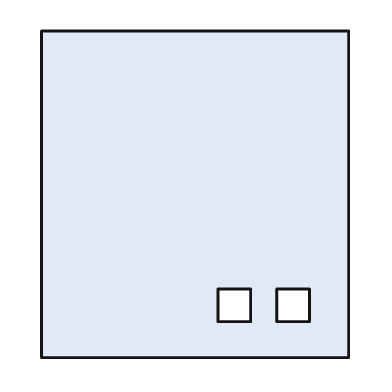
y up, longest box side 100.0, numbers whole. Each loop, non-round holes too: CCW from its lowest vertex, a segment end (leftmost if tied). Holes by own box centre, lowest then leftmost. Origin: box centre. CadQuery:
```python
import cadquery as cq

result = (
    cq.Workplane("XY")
    .moveTo(-47.0, -50.0)
    .lineTo(47.0, -50.0)
    .lineTo(47.0, 50.0)
    .lineTo(-47.0, 50.0)
    .close()
    .moveTo(7.0, -39.0)
    .lineTo(17.0, -39.0)
    .lineTo(17.0, -29.0)
    .lineTo(7.0, -29.0)
    .close()
    .moveTo(25.0, -39.0)
    .lineTo(35.0, -39.0)
    .lineTo(35.0, -29.0)
    .lineTo(25.0, -29.0)
    .close()
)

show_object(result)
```